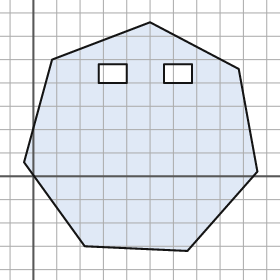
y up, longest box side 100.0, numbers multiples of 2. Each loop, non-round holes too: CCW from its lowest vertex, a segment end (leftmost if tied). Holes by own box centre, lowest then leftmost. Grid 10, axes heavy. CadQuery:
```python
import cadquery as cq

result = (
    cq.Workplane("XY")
    .moveTo(66.0, -32.0)
    .lineTo(96.0, 2.0)
    .lineTo(88.0, 46.0)
    .lineTo(50.0, 66.0)
    .lineTo(8.0, 50.0)
    .lineTo(-4.0, 6.0)
    .lineTo(22.0, -30.0)
    .close()
    .moveTo(28.0, 40.0)
    .lineTo(40.0, 40.0)
    .lineTo(40.0, 48.0)
    .lineTo(28.0, 48.0)
    .close()
    .moveTo(56.0, 40.0)
    .lineTo(68.0, 40.0)
    .lineTo(68.0, 48.0)
    .lineTo(56.0, 48.0)
    .close()
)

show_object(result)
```